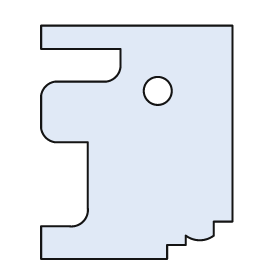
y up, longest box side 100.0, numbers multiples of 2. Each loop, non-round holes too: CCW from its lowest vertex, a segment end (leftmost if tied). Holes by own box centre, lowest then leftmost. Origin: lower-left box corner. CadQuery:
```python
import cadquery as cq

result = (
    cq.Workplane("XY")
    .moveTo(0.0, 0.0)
    .lineTo(54.0, 0.0)
    .lineTo(54.0, 6.0)
    .lineTo(62.0, 6.0)
    .lineTo(62.0, 10.0)
    .threePointArc((68.0, 8.0), (74.0, 10.0))
    .lineTo(74.0, 16.0)
    .lineTo(82.0, 16.0)
    .lineTo(82.0, 100.0)
    .lineTo(0.0, 100.0)
    .lineTo(0.0, 90.0)
    .lineTo(34.0, 90.0)
    .lineTo(34.0, 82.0)
    .threePointArc((32.0, 78.0), (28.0, 76.0))
    .lineTo(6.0, 76.0)
    .threePointArc((2.0, 74.0), (0.0, 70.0))
    .lineTo(0.0, 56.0)
    .threePointArc((2.0, 52.0), (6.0, 50.0))
    .lineTo(20.0, 50.0)
    .lineTo(20.0, 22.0)
    .threePointArc((18.0, 16.0), (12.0, 14.0))
    .lineTo(0.0, 14.0)
    .close()
    .moveTo(50.0, 72.0)
    .circle(6.0)
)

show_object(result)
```